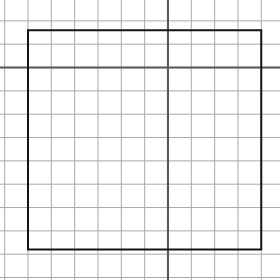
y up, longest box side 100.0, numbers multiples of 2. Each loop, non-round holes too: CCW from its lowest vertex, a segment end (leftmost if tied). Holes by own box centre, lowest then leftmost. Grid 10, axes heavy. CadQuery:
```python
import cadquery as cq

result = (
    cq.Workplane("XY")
    .moveTo(-60.0, -78.0)
    .lineTo(40.0, -78.0)
    .lineTo(40.0, 16.0)
    .lineTo(-60.0, 16.0)
    .close()
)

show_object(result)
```